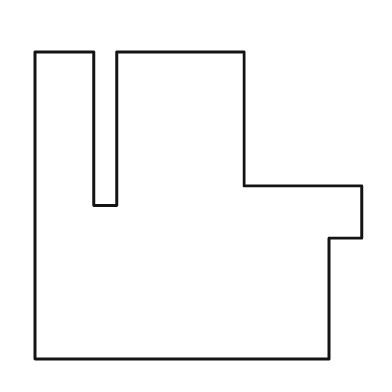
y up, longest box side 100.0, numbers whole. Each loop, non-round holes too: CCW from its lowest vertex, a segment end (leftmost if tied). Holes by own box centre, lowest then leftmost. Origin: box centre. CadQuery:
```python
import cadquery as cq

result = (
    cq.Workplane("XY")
    .moveTo(-50.0, -47.0)
    .lineTo(40.0, -47.0)
    .lineTo(40.0, -10.0)
    .lineTo(50.0, -10.0)
    .lineTo(50.0, 6.0)
    .lineTo(14.0, 6.0)
    .lineTo(14.0, 47.0)
    .lineTo(-25.0, 47.0)
    .lineTo(-25.0, 0.0)
    .lineTo(-32.0, 0.0)
    .lineTo(-32.0, 47.0)
    .lineTo(-50.0, 47.0)
    .close()
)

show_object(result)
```